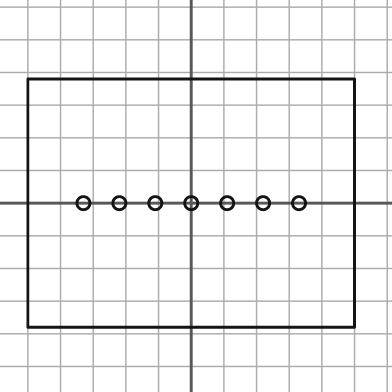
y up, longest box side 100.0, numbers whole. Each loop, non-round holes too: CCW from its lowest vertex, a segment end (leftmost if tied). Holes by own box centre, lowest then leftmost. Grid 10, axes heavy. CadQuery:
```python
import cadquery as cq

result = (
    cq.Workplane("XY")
    .moveTo(-50.0, -38.0)
    .lineTo(50.0, -38.0)
    .lineTo(50.0, 38.0)
    .lineTo(-50.0, 38.0)
    .close()
    .moveTo(-33.0, 0.0)
    .circle(2.0)
    .moveTo(-22.0, 0.0)
    .circle(2.0)
    .moveTo(-11.0, 0.0)
    .circle(2.0)
    .moveTo(0.0, 0.0)
    .circle(2.0)
    .moveTo(11.0, 0.0)
    .circle(2.0)
    .moveTo(22.0, 0.0)
    .circle(2.0)
    .moveTo(33.0, 0.0)
    .circle(2.0)
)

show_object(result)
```